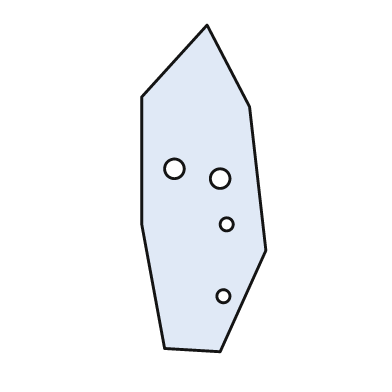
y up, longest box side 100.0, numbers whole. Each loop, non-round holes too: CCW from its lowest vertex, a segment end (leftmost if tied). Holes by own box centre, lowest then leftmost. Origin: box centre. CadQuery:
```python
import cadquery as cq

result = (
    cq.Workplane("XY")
    .moveTo(5.0, -50.0)
    .lineTo(19.0, -19.0)
    .lineTo(14.0, 25.0)
    .lineTo(1.0, 50.0)
    .lineTo(-19.0, 28.0)
    .lineTo(-19.0, -11.0)
    .lineTo(-12.0, -49.0)
    .close()
    .moveTo(6.0, -33.0)
    .circle(2.0)
    .moveTo(7.0, -11.0)
    .circle(2.0)
    .moveTo(5.0, 3.0)
    .circle(3.0)
    .moveTo(-9.0, 6.0)
    .circle(3.0)
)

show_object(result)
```